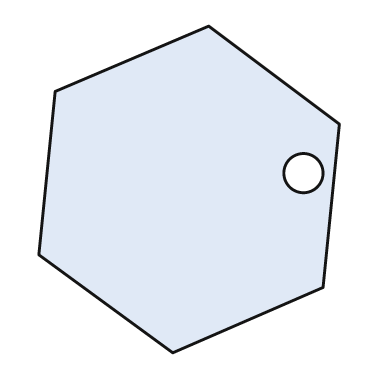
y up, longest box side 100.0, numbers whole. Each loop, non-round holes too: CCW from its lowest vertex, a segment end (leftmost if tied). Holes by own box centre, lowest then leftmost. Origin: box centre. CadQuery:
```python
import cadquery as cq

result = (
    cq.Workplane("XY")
    .moveTo(-5.0, -50.0)
    .lineTo(41.0, -30.0)
    .lineTo(46.0, 20.0)
    .lineTo(6.0, 50.0)
    .lineTo(-41.0, 30.0)
    .lineTo(-46.0, -20.0)
    .close()
    .moveTo(35.0, 5.0)
    .circle(6.0)
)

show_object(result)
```